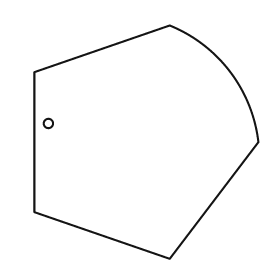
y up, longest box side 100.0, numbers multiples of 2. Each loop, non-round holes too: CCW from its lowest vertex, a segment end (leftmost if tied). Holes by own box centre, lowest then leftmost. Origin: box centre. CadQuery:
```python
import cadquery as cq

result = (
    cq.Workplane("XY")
    .moveTo(10.0, -50.0)
    .lineTo(48.0, 0.0)
    .threePointArc((36.0, 30.0), (10.0, 50.0))
    .lineTo(-48.0, 30.0)
    .lineTo(-48.0, -30.0)
    .close()
    .moveTo(-42.0, 8.0)
    .circle(2.0)
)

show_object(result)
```